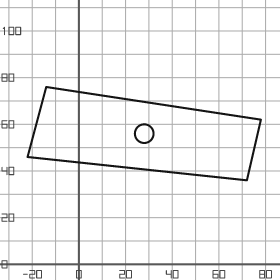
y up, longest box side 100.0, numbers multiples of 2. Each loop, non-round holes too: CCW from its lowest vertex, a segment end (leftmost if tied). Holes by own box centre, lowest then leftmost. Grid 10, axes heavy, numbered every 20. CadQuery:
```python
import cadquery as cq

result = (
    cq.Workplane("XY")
    .moveTo(72.0, 36.0)
    .lineTo(78.0, 62.0)
    .lineTo(-14.0, 76.0)
    .lineTo(-22.0, 46.0)
    .close()
    .moveTo(28.0, 56.0)
    .circle(4.0)
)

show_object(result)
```